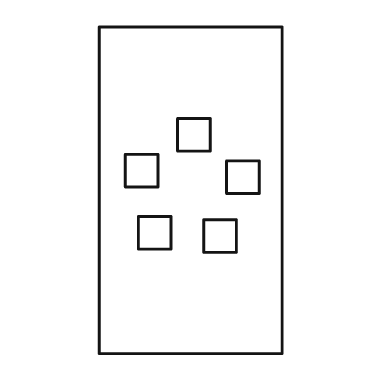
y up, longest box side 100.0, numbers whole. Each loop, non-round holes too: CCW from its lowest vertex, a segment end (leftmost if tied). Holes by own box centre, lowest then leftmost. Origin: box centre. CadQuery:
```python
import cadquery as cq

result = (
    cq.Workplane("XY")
    .moveTo(-28.0, -50.0)
    .lineTo(28.0, -50.0)
    .lineTo(28.0, 50.0)
    .lineTo(-28.0, 50.0)
    .close()
    .moveTo(4.0, -19.0)
    .lineTo(14.0, -19.0)
    .lineTo(14.0, -9.0)
    .lineTo(4.0, -9.0)
    .close()
    .moveTo(-16.0, -18.0)
    .lineTo(-6.0, -18.0)
    .lineTo(-6.0, -8.0)
    .lineTo(-16.0, -8.0)
    .close()
    .moveTo(11.0, -1.0)
    .lineTo(21.0, -1.0)
    .lineTo(21.0, 9.0)
    .lineTo(11.0, 9.0)
    .close()
    .moveTo(-20.0, 1.0)
    .lineTo(-10.0, 1.0)
    .lineTo(-10.0, 11.0)
    .lineTo(-20.0, 11.0)
    .close()
    .moveTo(-4.0, 12.0)
    .lineTo(6.0, 12.0)
    .lineTo(6.0, 22.0)
    .lineTo(-4.0, 22.0)
    .close()
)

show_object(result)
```